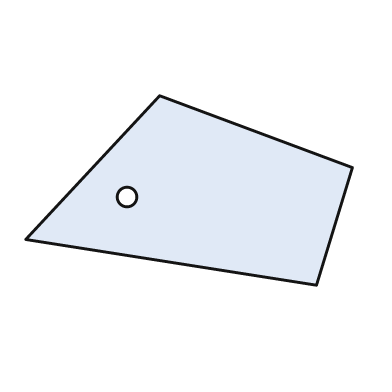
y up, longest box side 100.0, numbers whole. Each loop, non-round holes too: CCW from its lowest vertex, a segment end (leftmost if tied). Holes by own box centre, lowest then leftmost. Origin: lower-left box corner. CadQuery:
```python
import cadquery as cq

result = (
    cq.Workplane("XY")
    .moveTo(89.0, 0.0)
    .lineTo(100.0, 36.0)
    .lineTo(41.0, 58.0)
    .lineTo(0.0, 14.0)
    .close()
    .moveTo(31.0, 27.0)
    .circle(3.0)
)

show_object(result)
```